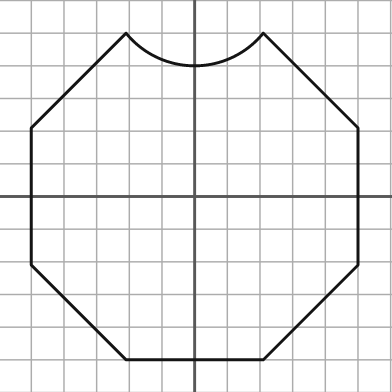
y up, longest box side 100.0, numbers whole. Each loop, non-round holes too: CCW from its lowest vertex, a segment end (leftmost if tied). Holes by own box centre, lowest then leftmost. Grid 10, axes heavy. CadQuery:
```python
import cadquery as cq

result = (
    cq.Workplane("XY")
    .moveTo(-21.0, -50.0)
    .lineTo(21.0, -50.0)
    .lineTo(50.0, -21.0)
    .lineTo(50.0, 21.0)
    .lineTo(21.0, 50.0)
    .threePointArc((0.0, 40.0), (-21.0, 50.0))
    .lineTo(-50.0, 21.0)
    .lineTo(-50.0, -21.0)
    .close()
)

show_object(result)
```